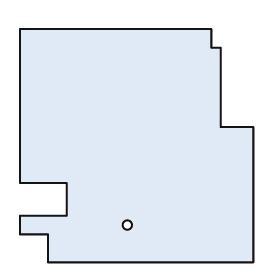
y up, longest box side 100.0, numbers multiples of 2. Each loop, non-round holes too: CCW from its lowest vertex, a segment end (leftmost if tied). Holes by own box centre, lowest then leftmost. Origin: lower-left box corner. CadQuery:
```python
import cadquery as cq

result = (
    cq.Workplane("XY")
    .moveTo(12.0, 0.0)
    .lineTo(100.0, 0.0)
    .lineTo(100.0, 58.0)
    .lineTo(86.0, 58.0)
    .lineTo(86.0, 92.0)
    .lineTo(82.0, 92.0)
    .lineTo(82.0, 100.0)
    .lineTo(0.0, 100.0)
    .lineTo(0.0, 34.0)
    .lineTo(20.0, 34.0)
    .lineTo(20.0, 20.0)
    .lineTo(0.0, 20.0)
    .lineTo(0.0, 12.0)
    .lineTo(12.0, 12.0)
    .close()
    .moveTo(46.0, 16.0)
    .circle(2.0)
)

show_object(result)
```